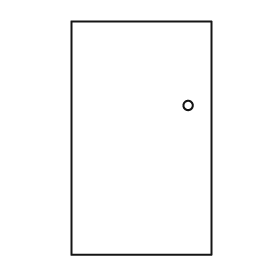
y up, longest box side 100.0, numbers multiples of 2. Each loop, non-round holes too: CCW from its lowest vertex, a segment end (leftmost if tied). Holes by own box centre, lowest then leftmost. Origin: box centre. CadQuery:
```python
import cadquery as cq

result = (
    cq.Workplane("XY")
    .moveTo(-30.0, -50.0)
    .lineTo(30.0, -50.0)
    .lineTo(30.0, 50.0)
    .lineTo(-30.0, 50.0)
    .close()
    .moveTo(20.0, 14.0)
    .circle(2.0)
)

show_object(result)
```